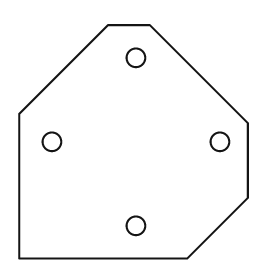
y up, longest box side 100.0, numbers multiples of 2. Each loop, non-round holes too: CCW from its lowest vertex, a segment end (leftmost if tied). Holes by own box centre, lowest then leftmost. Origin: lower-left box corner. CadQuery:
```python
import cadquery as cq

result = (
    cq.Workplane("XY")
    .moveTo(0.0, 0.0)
    .lineTo(72.0, 0.0)
    .lineTo(98.0, 26.0)
    .lineTo(98.0, 58.0)
    .lineTo(56.0, 100.0)
    .lineTo(38.0, 100.0)
    .lineTo(0.0, 62.0)
    .close()
    .moveTo(50.0, 14.0)
    .circle(4.0)
    .moveTo(14.0, 50.0)
    .circle(4.0)
    .moveTo(86.0, 50.0)
    .circle(4.0)
    .moveTo(50.0, 86.0)
    .circle(4.0)
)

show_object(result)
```